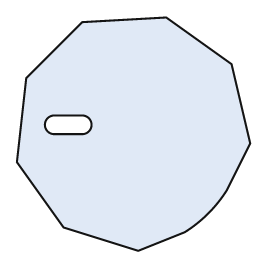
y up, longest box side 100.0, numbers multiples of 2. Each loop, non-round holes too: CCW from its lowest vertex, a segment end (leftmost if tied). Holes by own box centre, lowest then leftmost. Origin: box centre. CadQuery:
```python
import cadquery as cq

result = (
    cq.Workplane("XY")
    .moveTo(2.0, -50.0)
    .lineTo(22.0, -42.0)
    .threePointArc((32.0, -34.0), (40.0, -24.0))
    .lineTo(50.0, -4.0)
    .lineTo(42.0, 30.0)
    .lineTo(14.0, 50.0)
    .lineTo(-22.0, 48.0)
    .lineTo(-46.0, 24.0)
    .lineTo(-50.0, -12.0)
    .lineTo(-30.0, -40.0)
    .close()
    .moveTo(-34.0, 0.0)
    .lineTo(-22.0, 0.0)
    .threePointArc((-18.0, 4.0), (-22.0, 8.0))
    .lineTo(-34.0, 8.0)
    .threePointArc((-38.0, 4.0), (-34.0, 0.0))
    .close()
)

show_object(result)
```